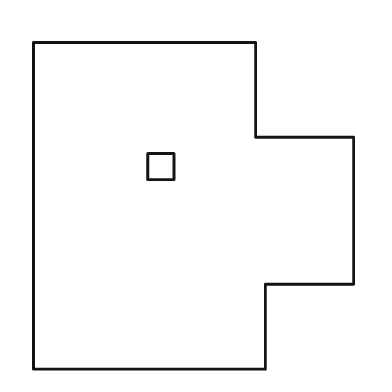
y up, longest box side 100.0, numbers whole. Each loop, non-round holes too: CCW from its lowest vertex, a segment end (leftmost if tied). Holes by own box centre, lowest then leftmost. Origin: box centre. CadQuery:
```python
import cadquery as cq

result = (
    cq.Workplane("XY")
    .moveTo(-49.0, -50.0)
    .lineTo(22.0, -50.0)
    .lineTo(22.0, -24.0)
    .lineTo(49.0, -24.0)
    .lineTo(49.0, 21.0)
    .lineTo(19.0, 21.0)
    .lineTo(19.0, 50.0)
    .lineTo(-49.0, 50.0)
    .close()
    .moveTo(-14.0, 8.0)
    .lineTo(-6.0, 8.0)
    .lineTo(-6.0, 16.0)
    .lineTo(-14.0, 16.0)
    .close()
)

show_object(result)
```